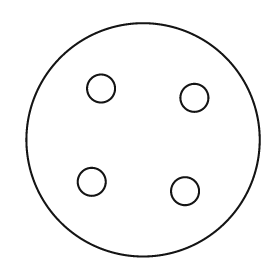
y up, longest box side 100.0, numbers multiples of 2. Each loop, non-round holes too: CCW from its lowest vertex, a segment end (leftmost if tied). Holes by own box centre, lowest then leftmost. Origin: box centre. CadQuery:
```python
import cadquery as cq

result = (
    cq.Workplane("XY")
    .moveTo(0.0, 0.0)
    .circle(50.0)
    .moveTo(18.0, -22.0)
    .circle(6.0)
    .moveTo(-22.0, -18.0)
    .circle(6.0)
    .moveTo(22.0, 18.0)
    .circle(6.0)
    .moveTo(-18.0, 22.0)
    .circle(6.0)
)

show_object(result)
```